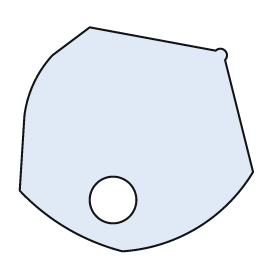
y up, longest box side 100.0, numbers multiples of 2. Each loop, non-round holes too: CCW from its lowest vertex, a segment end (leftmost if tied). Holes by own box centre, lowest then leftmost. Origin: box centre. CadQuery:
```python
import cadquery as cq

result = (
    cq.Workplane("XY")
    .moveTo(-6.0, -48.0)
    .threePointArc((26.0, -38.0), (50.0, -14.0))
    .lineTo(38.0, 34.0)
    .threePointArc((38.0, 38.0), (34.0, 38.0))
    .lineTo(-20.0, 48.0)
    .lineTo(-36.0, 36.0)
    .threePointArc((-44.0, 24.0), (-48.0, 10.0))
    .lineTo(-50.0, -22.0)
    .threePointArc((-30.0, -38.0), (-6.0, -48.0))
    .close()
    .moveTo(-10.0, -26.0)
    .circle(10.0)
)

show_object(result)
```